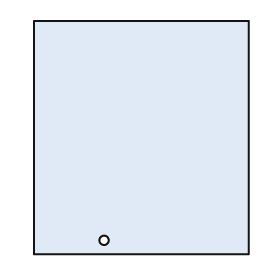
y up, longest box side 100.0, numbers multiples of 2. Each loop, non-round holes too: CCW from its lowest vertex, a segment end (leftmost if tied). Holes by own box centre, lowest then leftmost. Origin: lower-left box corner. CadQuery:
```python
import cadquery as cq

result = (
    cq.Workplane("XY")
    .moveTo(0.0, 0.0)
    .lineTo(92.0, 0.0)
    .lineTo(92.0, 100.0)
    .lineTo(0.0, 100.0)
    .close()
    .moveTo(30.0, 6.0)
    .circle(2.0)
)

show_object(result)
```